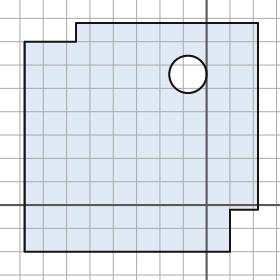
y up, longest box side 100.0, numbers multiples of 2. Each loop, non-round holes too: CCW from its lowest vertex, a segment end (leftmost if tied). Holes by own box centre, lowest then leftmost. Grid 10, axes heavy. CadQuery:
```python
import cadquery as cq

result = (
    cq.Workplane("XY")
    .moveTo(-78.0, -20.0)
    .lineTo(10.0, -20.0)
    .lineTo(10.0, -2.0)
    .lineTo(22.0, -2.0)
    .lineTo(22.0, 78.0)
    .lineTo(-56.0, 78.0)
    .lineTo(-56.0, 70.0)
    .lineTo(-78.0, 70.0)
    .close()
    .moveTo(-8.0, 56.0)
    .circle(8.0)
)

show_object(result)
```